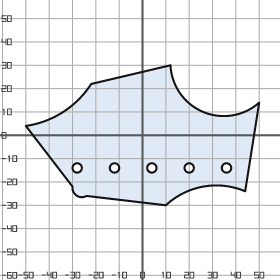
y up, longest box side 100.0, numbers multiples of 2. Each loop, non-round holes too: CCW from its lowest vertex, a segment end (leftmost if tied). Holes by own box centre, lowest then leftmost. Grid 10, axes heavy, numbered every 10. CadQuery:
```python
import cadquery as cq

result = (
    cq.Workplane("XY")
    .moveTo(10.0, -30.0)
    .threePointArc((26.0, -22.0), (44.0, -24.0))
    .lineTo(50.0, 14.0)
    .threePointArc((26.0, 10.0), (12.0, 30.0))
    .lineTo(-22.0, 22.0)
    .threePointArc((-34.0, 10.0), (-50.0, 4.0))
    .lineTo(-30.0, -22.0)
    .threePointArc((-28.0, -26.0), (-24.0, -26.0))
    .close()
    .moveTo(-28.0, -14.0)
    .circle(2.0)
    .moveTo(-12.0, -14.0)
    .circle(2.0)
    .moveTo(4.0, -14.0)
    .circle(2.0)
    .moveTo(20.0, -14.0)
    .circle(2.0)
    .moveTo(36.0, -14.0)
    .circle(2.0)
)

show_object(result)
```